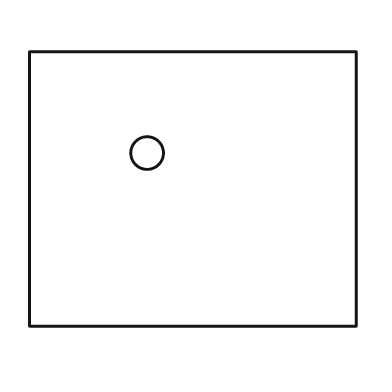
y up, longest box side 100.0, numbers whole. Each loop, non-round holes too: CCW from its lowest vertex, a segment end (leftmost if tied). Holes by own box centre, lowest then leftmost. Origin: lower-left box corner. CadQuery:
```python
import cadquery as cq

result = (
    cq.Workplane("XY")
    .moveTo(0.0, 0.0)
    .lineTo(100.0, 0.0)
    .lineTo(100.0, 84.0)
    .lineTo(0.0, 84.0)
    .close()
    .moveTo(36.0, 53.0)
    .circle(5.0)
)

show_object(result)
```